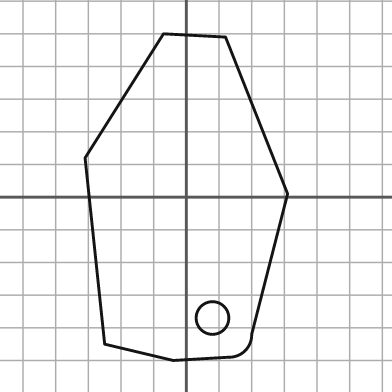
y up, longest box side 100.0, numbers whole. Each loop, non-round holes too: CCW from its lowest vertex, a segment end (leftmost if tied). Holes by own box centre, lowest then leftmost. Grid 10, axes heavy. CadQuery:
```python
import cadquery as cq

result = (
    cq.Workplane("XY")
    .moveTo(-4.0, -50.0)
    .lineTo(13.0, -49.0)
    .threePointArc((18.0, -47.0), (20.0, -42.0))
    .lineTo(31.0, 1.0)
    .lineTo(12.0, 49.0)
    .lineTo(-7.0, 50.0)
    .lineTo(-31.0, 12.0)
    .lineTo(-25.0, -45.0)
    .close()
    .moveTo(8.0, -37.0)
    .circle(5.0)
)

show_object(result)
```